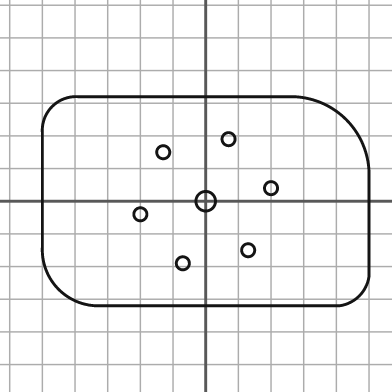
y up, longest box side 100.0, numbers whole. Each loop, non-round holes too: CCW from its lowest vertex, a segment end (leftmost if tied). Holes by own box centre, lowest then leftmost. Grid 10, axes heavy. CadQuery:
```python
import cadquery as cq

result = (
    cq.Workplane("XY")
    .moveTo(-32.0, -32.0)
    .lineTo(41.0, -32.0)
    .threePointArc((47.0, -29.0), (50.0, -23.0))
    .lineTo(50.0, 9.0)
    .threePointArc((43.0, 25.0), (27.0, 32.0))
    .lineTo(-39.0, 32.0)
    .threePointArc((-47.0, 29.0), (-50.0, 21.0))
    .lineTo(-50.0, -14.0)
    .threePointArc((-45.0, -27.0), (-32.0, -32.0))
    .close()
    .moveTo(-7.0, -19.0)
    .circle(2.0)
    .moveTo(13.0, -15.0)
    .circle(2.0)
    .moveTo(-20.0, -4.0)
    .circle(2.0)
    .moveTo(0.0, 0.0)
    .circle(3.0)
    .moveTo(20.0, 4.0)
    .circle(2.0)
    .moveTo(-13.0, 15.0)
    .circle(2.0)
    .moveTo(7.0, 19.0)
    .circle(2.0)
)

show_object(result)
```